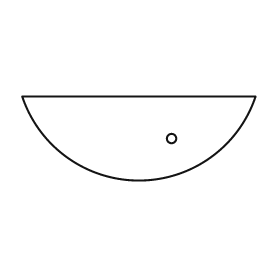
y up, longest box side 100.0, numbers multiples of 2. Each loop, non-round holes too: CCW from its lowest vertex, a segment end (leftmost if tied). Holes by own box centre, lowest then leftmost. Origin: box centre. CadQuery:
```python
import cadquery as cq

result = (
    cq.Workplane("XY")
    .moveTo(-50.0, 18.0)
    .threePointArc((0.0, -18.0), (50.0, 18.0))
    .close()
    .moveTo(14.0, 0.0)
    .circle(2.0)
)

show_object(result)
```